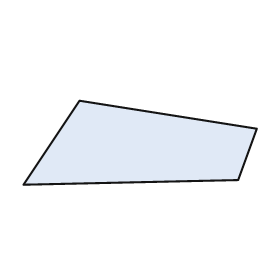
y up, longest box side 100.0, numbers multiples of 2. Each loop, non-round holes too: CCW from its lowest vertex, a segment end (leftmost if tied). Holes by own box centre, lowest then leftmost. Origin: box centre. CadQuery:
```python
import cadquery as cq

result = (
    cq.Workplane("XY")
    .moveTo(-50.0, -18.0)
    .lineTo(42.0, -16.0)
    .lineTo(50.0, 6.0)
    .lineTo(-26.0, 18.0)
    .close()
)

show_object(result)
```